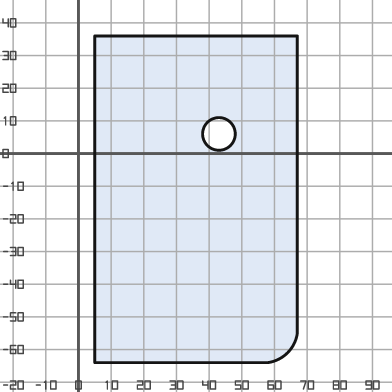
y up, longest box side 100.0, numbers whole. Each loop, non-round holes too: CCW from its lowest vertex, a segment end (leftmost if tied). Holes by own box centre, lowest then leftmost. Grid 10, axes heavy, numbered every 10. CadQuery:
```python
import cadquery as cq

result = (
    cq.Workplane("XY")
    .moveTo(5.0, -64.0)
    .lineTo(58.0, -64.0)
    .threePointArc((64.0, -61.0), (67.0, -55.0))
    .lineTo(67.0, 36.0)
    .lineTo(5.0, 36.0)
    .close()
    .moveTo(43.0, 6.0)
    .circle(5.0)
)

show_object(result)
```